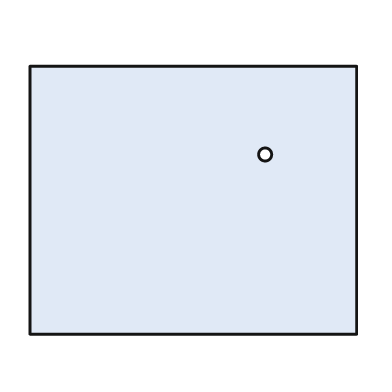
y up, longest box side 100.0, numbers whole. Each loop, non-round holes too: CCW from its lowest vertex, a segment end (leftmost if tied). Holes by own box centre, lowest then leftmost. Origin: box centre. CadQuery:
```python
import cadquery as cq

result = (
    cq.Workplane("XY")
    .moveTo(-50.0, -41.0)
    .lineTo(50.0, -41.0)
    .lineTo(50.0, 41.0)
    .lineTo(-50.0, 41.0)
    .close()
    .moveTo(22.0, 14.0)
    .circle(2.0)
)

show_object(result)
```